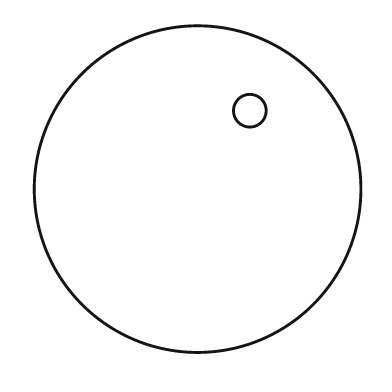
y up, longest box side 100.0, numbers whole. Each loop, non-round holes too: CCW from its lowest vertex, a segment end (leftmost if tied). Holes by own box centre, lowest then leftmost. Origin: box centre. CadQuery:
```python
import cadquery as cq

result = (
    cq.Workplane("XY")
    .moveTo(0.0, 0.0)
    .circle(50.0)
    .moveTo(16.0, 24.0)
    .circle(5.0)
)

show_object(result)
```